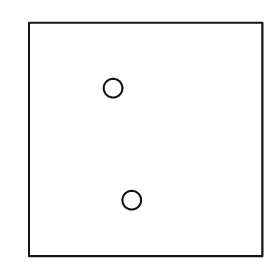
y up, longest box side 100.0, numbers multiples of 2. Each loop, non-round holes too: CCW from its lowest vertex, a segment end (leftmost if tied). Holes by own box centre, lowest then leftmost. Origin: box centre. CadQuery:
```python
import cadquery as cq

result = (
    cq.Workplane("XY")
    .moveTo(-50.0, -50.0)
    .lineTo(50.0, -50.0)
    .lineTo(50.0, 50.0)
    .lineTo(-50.0, 50.0)
    .close()
    .moveTo(-6.0, -26.0)
    .circle(4.0)
    .moveTo(-14.0, 22.0)
    .circle(4.0)
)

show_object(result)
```